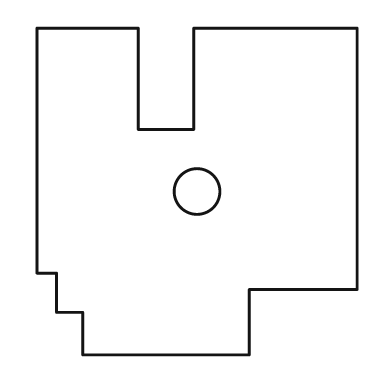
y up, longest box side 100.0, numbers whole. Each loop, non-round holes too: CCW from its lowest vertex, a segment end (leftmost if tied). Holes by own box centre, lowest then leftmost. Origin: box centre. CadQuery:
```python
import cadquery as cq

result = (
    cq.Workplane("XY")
    .moveTo(-35.0, -50.0)
    .lineTo(16.0, -50.0)
    .lineTo(16.0, -30.0)
    .lineTo(49.0, -30.0)
    .lineTo(49.0, 50.0)
    .lineTo(-1.0, 50.0)
    .lineTo(-1.0, 19.0)
    .lineTo(-18.0, 19.0)
    .lineTo(-18.0, 50.0)
    .lineTo(-49.0, 50.0)
    .lineTo(-49.0, -25.0)
    .lineTo(-43.0, -25.0)
    .lineTo(-43.0, -37.0)
    .lineTo(-35.0, -37.0)
    .close()
    .moveTo(0.0, 0.0)
    .circle(7.0)
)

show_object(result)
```